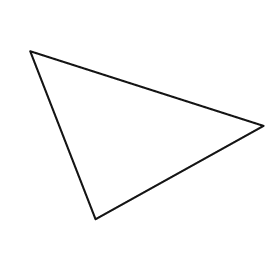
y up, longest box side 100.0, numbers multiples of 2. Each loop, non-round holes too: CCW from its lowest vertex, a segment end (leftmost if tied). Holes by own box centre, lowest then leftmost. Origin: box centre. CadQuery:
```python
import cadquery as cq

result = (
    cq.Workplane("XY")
    .moveTo(-22.0, -36.0)
    .lineTo(50.0, 4.0)
    .lineTo(-50.0, 36.0)
    .close()
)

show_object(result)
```